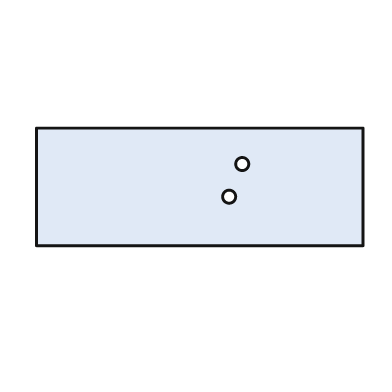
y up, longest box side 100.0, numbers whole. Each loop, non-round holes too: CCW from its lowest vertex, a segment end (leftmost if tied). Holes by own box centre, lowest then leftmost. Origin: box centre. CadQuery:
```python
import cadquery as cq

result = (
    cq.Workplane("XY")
    .moveTo(-50.0, -18.0)
    .lineTo(50.0, -18.0)
    .lineTo(50.0, 18.0)
    .lineTo(-50.0, 18.0)
    .close()
    .moveTo(9.0, -3.0)
    .circle(2.0)
    .moveTo(13.0, 7.0)
    .circle(2.0)
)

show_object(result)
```